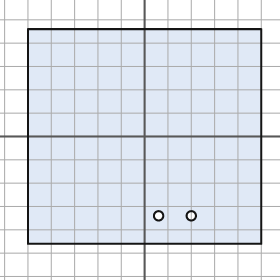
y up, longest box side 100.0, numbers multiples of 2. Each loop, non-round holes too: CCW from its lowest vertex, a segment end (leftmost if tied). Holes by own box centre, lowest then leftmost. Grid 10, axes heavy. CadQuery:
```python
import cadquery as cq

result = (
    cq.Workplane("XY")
    .moveTo(-50.0, -46.0)
    .lineTo(50.0, -46.0)
    .lineTo(50.0, 46.0)
    .lineTo(-50.0, 46.0)
    .close()
    .moveTo(6.0, -34.0)
    .circle(2.0)
    .moveTo(20.0, -34.0)
    .circle(2.0)
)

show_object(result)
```